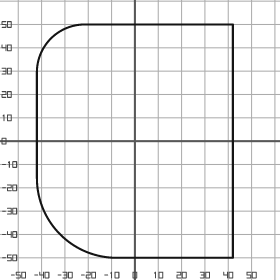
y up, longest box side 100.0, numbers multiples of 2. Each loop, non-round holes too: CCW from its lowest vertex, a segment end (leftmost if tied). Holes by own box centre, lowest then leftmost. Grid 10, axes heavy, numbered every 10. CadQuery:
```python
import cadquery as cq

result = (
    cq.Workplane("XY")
    .moveTo(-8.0, -50.0)
    .lineTo(42.0, -50.0)
    .lineTo(42.0, 50.0)
    .lineTo(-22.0, 50.0)
    .threePointArc((-36.0, 44.0), (-42.0, 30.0))
    .lineTo(-42.0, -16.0)
    .threePointArc((-32.0, -40.0), (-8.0, -50.0))
    .close()
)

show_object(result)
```